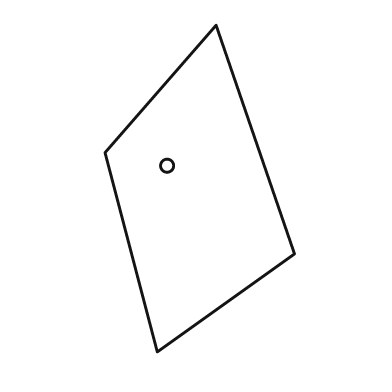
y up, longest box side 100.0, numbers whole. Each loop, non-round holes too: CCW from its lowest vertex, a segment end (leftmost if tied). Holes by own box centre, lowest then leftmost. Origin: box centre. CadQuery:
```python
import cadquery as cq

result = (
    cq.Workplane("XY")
    .moveTo(-13.0, -50.0)
    .lineTo(29.0, -20.0)
    .lineTo(5.0, 50.0)
    .lineTo(-29.0, 11.0)
    .close()
    .moveTo(-10.0, 7.0)
    .circle(2.0)
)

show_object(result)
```